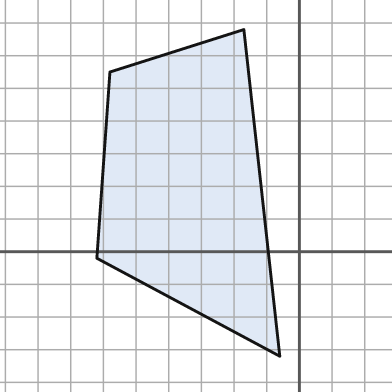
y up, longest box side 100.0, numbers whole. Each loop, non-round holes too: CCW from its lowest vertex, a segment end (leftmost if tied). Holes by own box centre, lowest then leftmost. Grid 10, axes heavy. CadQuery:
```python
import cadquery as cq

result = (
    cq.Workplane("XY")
    .moveTo(-6.0, -32.0)
    .lineTo(-17.0, 68.0)
    .lineTo(-58.0, 55.0)
    .lineTo(-62.0, -2.0)
    .close()
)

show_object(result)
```